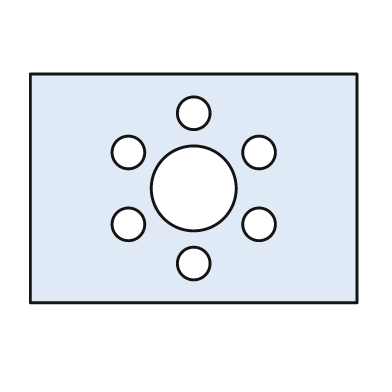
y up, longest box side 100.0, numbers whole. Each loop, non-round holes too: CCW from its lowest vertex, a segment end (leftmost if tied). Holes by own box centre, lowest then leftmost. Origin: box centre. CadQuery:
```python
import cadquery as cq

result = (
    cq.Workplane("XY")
    .moveTo(-50.0, -35.0)
    .lineTo(50.0, -35.0)
    .lineTo(50.0, 35.0)
    .lineTo(-50.0, 35.0)
    .close()
    .moveTo(0.0, -23.0)
    .circle(5.0)
    .moveTo(-20.0, -11.0)
    .circle(5.0)
    .moveTo(20.0, -11.0)
    .circle(5.0)
    .moveTo(0.0, 0.0)
    .circle(13.0)
    .moveTo(-20.0, 11.0)
    .circle(5.0)
    .moveTo(20.0, 11.0)
    .circle(5.0)
    .moveTo(0.0, 23.0)
    .circle(5.0)
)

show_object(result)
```